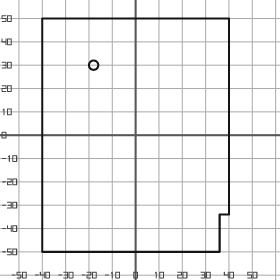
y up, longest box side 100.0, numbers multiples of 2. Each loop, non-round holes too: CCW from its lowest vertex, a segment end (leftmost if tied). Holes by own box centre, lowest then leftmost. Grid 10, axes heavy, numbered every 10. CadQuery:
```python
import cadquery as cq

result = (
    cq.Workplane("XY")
    .moveTo(-40.0, -50.0)
    .lineTo(36.0, -50.0)
    .lineTo(36.0, -34.0)
    .lineTo(40.0, -34.0)
    .lineTo(40.0, 50.0)
    .lineTo(-40.0, 50.0)
    .close()
    .moveTo(-18.0, 30.0)
    .circle(2.0)
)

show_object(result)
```